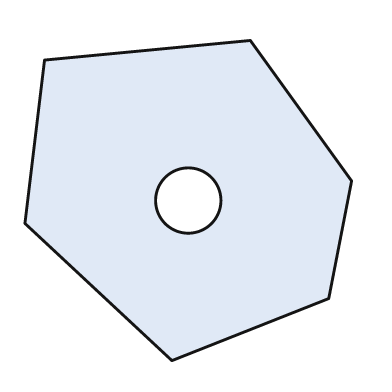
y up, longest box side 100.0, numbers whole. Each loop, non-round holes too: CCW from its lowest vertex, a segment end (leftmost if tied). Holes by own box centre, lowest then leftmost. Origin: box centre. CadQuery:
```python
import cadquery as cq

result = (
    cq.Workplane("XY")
    .moveTo(-5.0, -49.0)
    .lineTo(43.0, -30.0)
    .lineTo(50.0, 6.0)
    .lineTo(19.0, 49.0)
    .lineTo(-44.0, 43.0)
    .lineTo(-50.0, -7.0)
    .close()
    .moveTo(0.0, 0.0)
    .circle(10.0)
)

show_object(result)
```